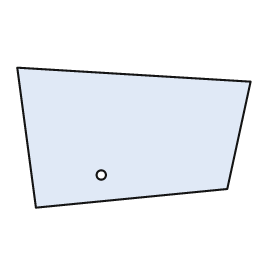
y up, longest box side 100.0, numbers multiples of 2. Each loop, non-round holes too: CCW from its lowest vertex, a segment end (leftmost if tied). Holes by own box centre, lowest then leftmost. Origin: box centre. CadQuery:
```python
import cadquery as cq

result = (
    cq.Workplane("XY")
    .moveTo(-42.0, -30.0)
    .lineTo(40.0, -22.0)
    .lineTo(50.0, 24.0)
    .lineTo(-50.0, 30.0)
    .close()
    .moveTo(-14.0, -16.0)
    .circle(2.0)
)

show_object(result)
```